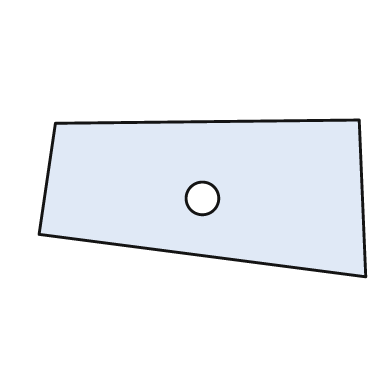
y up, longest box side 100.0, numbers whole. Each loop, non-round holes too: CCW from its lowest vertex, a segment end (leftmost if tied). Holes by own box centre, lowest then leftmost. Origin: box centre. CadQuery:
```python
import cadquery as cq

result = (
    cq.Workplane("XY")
    .moveTo(50.0, -24.0)
    .lineTo(48.0, 24.0)
    .lineTo(-45.0, 23.0)
    .lineTo(-50.0, -11.0)
    .close()
    .moveTo(0.0, 0.0)
    .circle(5.0)
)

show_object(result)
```